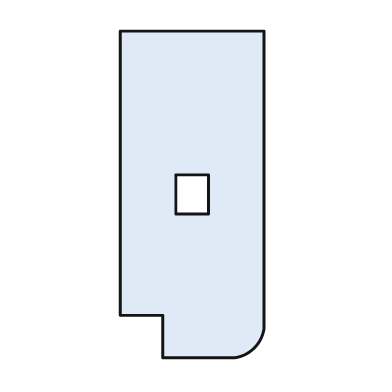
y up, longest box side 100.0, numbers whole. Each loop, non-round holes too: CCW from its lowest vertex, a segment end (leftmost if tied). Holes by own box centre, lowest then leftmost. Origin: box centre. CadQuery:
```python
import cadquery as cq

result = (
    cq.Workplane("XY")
    .moveTo(-9.0, -50.0)
    .lineTo(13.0, -50.0)
    .threePointArc((19.0, -47.0), (22.0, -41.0))
    .lineTo(22.0, 50.0)
    .lineTo(-22.0, 50.0)
    .lineTo(-22.0, -37.0)
    .lineTo(-9.0, -37.0)
    .close()
    .moveTo(-5.0, -6.0)
    .lineTo(5.0, -6.0)
    .lineTo(5.0, 6.0)
    .lineTo(-5.0, 6.0)
    .close()
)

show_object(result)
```